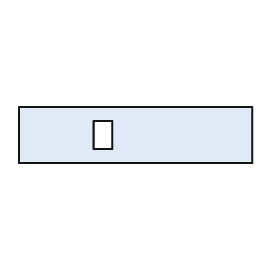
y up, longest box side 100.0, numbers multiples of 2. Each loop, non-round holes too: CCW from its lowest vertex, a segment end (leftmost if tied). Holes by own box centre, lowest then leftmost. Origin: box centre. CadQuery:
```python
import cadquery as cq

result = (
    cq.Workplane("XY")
    .moveTo(-50.0, -12.0)
    .lineTo(50.0, -12.0)
    .lineTo(50.0, 12.0)
    .lineTo(-50.0, 12.0)
    .close()
    .moveTo(-18.0, -6.0)
    .lineTo(-10.0, -6.0)
    .lineTo(-10.0, 6.0)
    .lineTo(-18.0, 6.0)
    .close()
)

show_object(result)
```